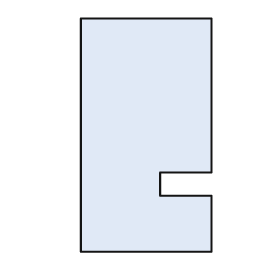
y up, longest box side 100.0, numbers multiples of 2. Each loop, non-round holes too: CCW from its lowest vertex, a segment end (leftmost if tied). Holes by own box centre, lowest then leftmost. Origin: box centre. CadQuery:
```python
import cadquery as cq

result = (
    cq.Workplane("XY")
    .moveTo(-28.0, -50.0)
    .lineTo(28.0, -50.0)
    .lineTo(28.0, -26.0)
    .lineTo(6.0, -26.0)
    .lineTo(6.0, -16.0)
    .lineTo(28.0, -16.0)
    .lineTo(28.0, 50.0)
    .lineTo(-28.0, 50.0)
    .close()
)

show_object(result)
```